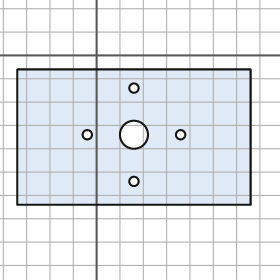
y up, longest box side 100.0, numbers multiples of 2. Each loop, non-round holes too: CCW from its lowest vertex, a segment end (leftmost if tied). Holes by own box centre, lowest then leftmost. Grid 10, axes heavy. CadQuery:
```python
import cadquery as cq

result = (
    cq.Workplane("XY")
    .moveTo(-34.0, -64.0)
    .lineTo(66.0, -64.0)
    .lineTo(66.0, -6.0)
    .lineTo(-34.0, -6.0)
    .close()
    .moveTo(16.0, -54.0)
    .circle(2.0)
    .moveTo(-4.0, -34.0)
    .circle(2.0)
    .moveTo(16.0, -34.0)
    .circle(6.0)
    .moveTo(36.0, -34.0)
    .circle(2.0)
    .moveTo(16.0, -14.0)
    .circle(2.0)
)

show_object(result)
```